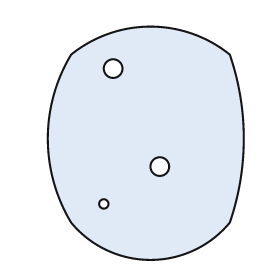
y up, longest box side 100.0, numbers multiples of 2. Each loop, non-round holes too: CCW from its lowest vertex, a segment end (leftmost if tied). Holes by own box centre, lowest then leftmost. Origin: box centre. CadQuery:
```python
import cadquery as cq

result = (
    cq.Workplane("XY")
    .moveTo(-32.0, -34.0)
    .threePointArc((2.0, -50.0), (36.0, -34.0))
    .threePointArc((42.0, 2.0), (36.0, 38.0))
    .threePointArc((2.0, 50.0), (-32.0, 38.0))
    .threePointArc((-42.0, 2.0), (-32.0, -34.0))
    .close()
    .moveTo(-18.0, -26.0)
    .circle(2.0)
    .moveTo(6.0, -10.0)
    .circle(4.0)
    .moveTo(-14.0, 32.0)
    .circle(4.0)
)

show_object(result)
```